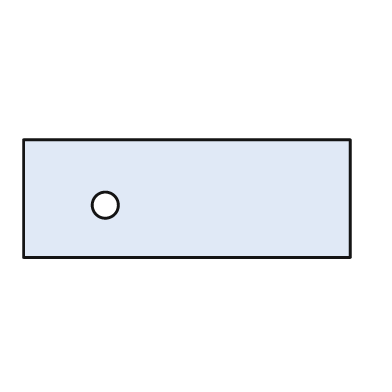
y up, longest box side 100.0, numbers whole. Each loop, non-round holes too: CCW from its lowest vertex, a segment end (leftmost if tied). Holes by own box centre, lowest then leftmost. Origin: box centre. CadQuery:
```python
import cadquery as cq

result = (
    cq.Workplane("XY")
    .moveTo(-50.0, -18.0)
    .lineTo(50.0, -18.0)
    .lineTo(50.0, 18.0)
    .lineTo(-50.0, 18.0)
    .close()
    .moveTo(-25.0, -2.0)
    .circle(4.0)
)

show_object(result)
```